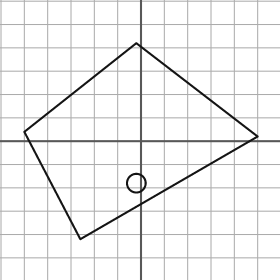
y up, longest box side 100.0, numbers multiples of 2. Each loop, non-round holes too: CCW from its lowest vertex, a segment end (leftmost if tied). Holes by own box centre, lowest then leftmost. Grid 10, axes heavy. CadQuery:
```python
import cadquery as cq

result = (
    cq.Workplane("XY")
    .moveTo(-26.0, -42.0)
    .lineTo(50.0, 2.0)
    .lineTo(-2.0, 42.0)
    .lineTo(-50.0, 4.0)
    .close()
    .moveTo(-2.0, -18.0)
    .circle(4.0)
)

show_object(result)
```